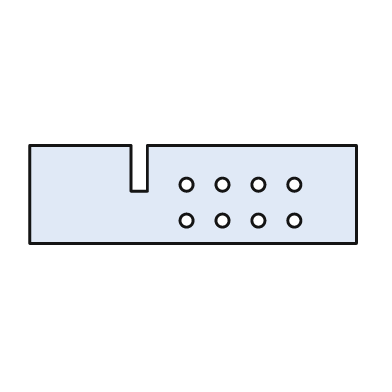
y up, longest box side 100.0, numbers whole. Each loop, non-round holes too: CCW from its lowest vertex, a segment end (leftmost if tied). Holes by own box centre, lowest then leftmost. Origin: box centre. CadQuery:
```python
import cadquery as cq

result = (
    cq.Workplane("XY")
    .moveTo(-50.0, -15.0)
    .lineTo(50.0, -15.0)
    .lineTo(50.0, 15.0)
    .lineTo(-14.0, 15.0)
    .lineTo(-14.0, 1.0)
    .lineTo(-19.0, 1.0)
    .lineTo(-19.0, 15.0)
    .lineTo(-50.0, 15.0)
    .close()
    .moveTo(-2.0, -8.0)
    .circle(2.0)
    .moveTo(9.0, -8.0)
    .circle(2.0)
    .moveTo(20.0, -8.0)
    .circle(2.0)
    .moveTo(31.0, -8.0)
    .circle(2.0)
    .moveTo(-2.0, 3.0)
    .circle(2.0)
    .moveTo(9.0, 3.0)
    .circle(2.0)
    .moveTo(20.0, 3.0)
    .circle(2.0)
    .moveTo(31.0, 3.0)
    .circle(2.0)
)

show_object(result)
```